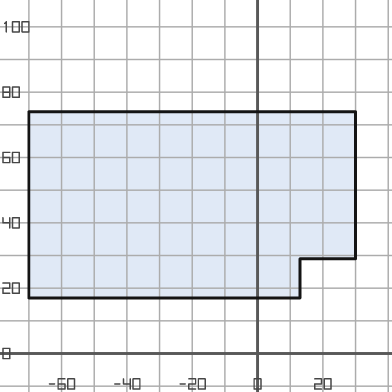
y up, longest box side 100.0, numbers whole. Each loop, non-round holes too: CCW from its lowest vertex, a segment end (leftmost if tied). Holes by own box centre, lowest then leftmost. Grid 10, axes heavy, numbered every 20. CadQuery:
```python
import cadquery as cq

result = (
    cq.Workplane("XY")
    .moveTo(-70.0, 17.0)
    .lineTo(13.0, 17.0)
    .lineTo(13.0, 29.0)
    .lineTo(30.0, 29.0)
    .lineTo(30.0, 74.0)
    .lineTo(-70.0, 74.0)
    .close()
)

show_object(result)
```